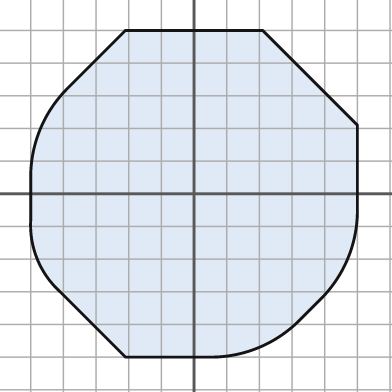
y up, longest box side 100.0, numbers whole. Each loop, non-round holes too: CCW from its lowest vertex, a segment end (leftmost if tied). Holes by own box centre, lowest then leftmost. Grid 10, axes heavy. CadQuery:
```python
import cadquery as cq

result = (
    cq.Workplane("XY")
    .moveTo(-21.0, -50.0)
    .lineTo(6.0, -50.0)
    .threePointArc((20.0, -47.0), (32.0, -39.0))
    .lineTo(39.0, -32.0)
    .threePointArc((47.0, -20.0), (50.0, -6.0))
    .lineTo(50.0, 21.0)
    .lineTo(21.0, 50.0)
    .lineTo(-21.0, 50.0)
    .lineTo(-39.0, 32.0)
    .threePointArc((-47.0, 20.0), (-50.0, 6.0))
    .lineTo(-50.0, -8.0)
    .threePointArc((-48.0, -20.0), (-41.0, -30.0))
    .close()
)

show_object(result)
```